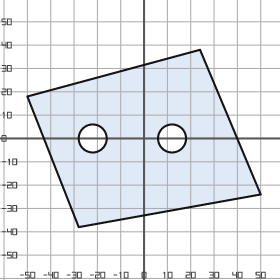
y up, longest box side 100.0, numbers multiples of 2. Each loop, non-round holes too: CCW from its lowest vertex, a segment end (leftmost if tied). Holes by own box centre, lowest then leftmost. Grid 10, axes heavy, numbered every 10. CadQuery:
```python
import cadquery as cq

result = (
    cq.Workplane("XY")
    .moveTo(-28.0, -38.0)
    .lineTo(50.0, -24.0)
    .lineTo(24.0, 38.0)
    .lineTo(-50.0, 18.0)
    .close()
    .moveTo(-22.0, 0.0)
    .circle(6.0)
    .moveTo(12.0, 0.0)
    .circle(6.0)
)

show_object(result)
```